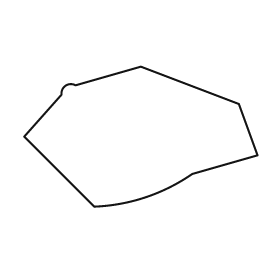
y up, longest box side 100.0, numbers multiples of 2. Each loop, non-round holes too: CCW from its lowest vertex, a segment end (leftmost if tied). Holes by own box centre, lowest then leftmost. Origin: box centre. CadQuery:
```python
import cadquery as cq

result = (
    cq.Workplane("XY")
    .moveTo(-20.0, -30.0)
    .threePointArc((2.0, -26.0), (22.0, -16.0))
    .lineTo(50.0, -8.0)
    .lineTo(42.0, 14.0)
    .lineTo(0.0, 30.0)
    .lineTo(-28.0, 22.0)
    .threePointArc((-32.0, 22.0), (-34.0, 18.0))
    .lineTo(-50.0, 0.0)
    .close()
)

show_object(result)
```